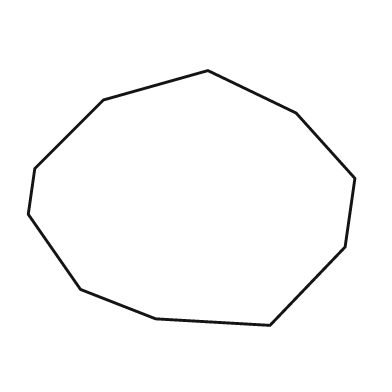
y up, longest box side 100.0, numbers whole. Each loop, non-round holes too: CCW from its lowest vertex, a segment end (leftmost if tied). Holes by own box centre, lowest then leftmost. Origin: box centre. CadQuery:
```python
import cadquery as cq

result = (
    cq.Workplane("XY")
    .moveTo(24.0, -39.0)
    .lineTo(47.0, -15.0)
    .lineTo(50.0, 6.0)
    .lineTo(32.0, 26.0)
    .lineTo(5.0, 39.0)
    .lineTo(-27.0, 30.0)
    .lineTo(-48.0, 9.0)
    .lineTo(-50.0, -5.0)
    .lineTo(-34.0, -28.0)
    .lineTo(-11.0, -37.0)
    .close()
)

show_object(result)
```